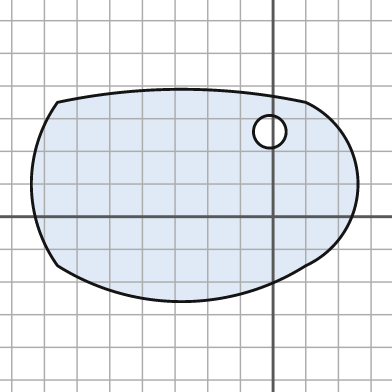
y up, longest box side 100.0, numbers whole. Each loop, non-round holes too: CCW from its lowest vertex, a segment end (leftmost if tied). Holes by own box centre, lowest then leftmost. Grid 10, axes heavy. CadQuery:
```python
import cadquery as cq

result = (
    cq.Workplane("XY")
    .moveTo(-66.0, -15.0)
    .threePointArc((-28.0, -26.0), (10.0, -15.0))
    .threePointArc((26.0, 10.0), (10.0, 35.0))
    .threePointArc((-28.0, 39.0), (-66.0, 35.0))
    .threePointArc((-74.0, 10.0), (-66.0, -15.0))
    .close()
    .moveTo(-1.0, 26.0)
    .circle(5.0)
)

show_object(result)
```